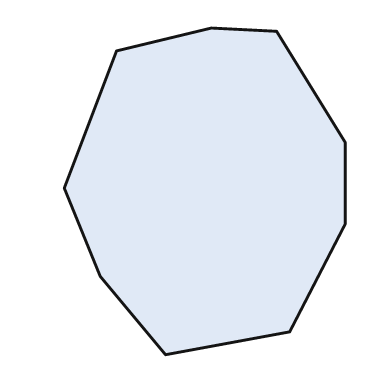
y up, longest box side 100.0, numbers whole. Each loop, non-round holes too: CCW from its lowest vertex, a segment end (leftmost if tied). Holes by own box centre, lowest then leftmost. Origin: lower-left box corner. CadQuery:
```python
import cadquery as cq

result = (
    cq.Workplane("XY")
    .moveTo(31.0, 0.0)
    .lineTo(69.0, 7.0)
    .lineTo(86.0, 40.0)
    .lineTo(86.0, 65.0)
    .lineTo(65.0, 99.0)
    .lineTo(45.0, 100.0)
    .lineTo(16.0, 93.0)
    .lineTo(0.0, 51.0)
    .lineTo(11.0, 24.0)
    .close()
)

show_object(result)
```